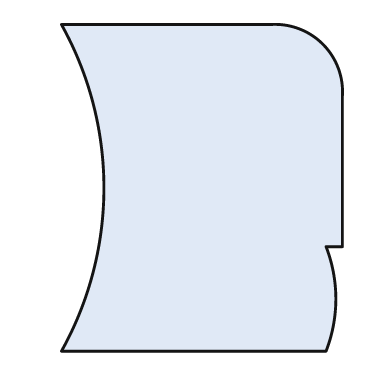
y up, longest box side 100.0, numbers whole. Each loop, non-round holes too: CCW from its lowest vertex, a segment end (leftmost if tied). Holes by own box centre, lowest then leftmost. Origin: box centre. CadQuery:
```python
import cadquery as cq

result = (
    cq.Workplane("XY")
    .moveTo(-43.0, -50.0)
    .lineTo(38.0, -50.0)
    .threePointArc((41.0, -34.0), (38.0, -18.0))
    .lineTo(43.0, -18.0)
    .lineTo(43.0, 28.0)
    .threePointArc((37.0, 44.0), (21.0, 50.0))
    .lineTo(-43.0, 50.0)
    .threePointArc((-30.0, 0.0), (-43.0, -50.0))
    .close()
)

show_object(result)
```